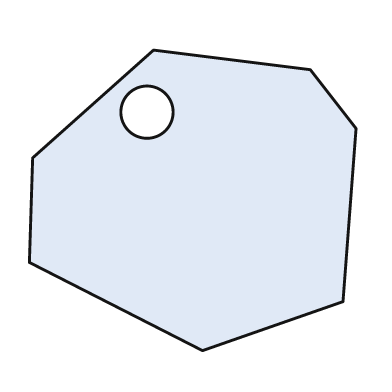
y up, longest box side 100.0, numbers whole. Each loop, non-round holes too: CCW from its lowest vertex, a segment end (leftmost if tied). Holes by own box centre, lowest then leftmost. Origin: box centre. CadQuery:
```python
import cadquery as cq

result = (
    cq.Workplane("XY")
    .moveTo(3.0, -46.0)
    .lineTo(46.0, -31.0)
    .lineTo(50.0, 22.0)
    .lineTo(36.0, 40.0)
    .lineTo(-12.0, 46.0)
    .lineTo(-49.0, 13.0)
    .lineTo(-50.0, -19.0)
    .close()
    .moveTo(-14.0, 27.0)
    .circle(8.0)
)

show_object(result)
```